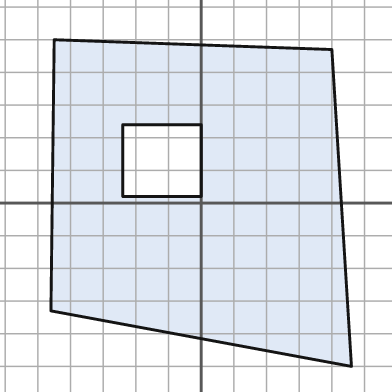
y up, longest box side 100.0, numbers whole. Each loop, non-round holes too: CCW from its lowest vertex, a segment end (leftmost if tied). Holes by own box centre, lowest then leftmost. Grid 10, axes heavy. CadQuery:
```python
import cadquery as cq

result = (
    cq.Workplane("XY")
    .moveTo(46.0, -50.0)
    .lineTo(40.0, 47.0)
    .lineTo(-45.0, 50.0)
    .lineTo(-46.0, -33.0)
    .close()
    .moveTo(-24.0, 2.0)
    .lineTo(0.0, 2.0)
    .lineTo(0.0, 24.0)
    .lineTo(-24.0, 24.0)
    .close()
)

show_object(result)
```